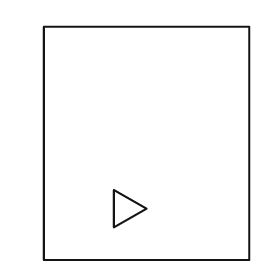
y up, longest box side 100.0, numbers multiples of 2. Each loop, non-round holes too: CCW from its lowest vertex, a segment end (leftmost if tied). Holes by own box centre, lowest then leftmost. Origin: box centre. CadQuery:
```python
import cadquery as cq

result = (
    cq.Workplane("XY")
    .moveTo(-44.0, -50.0)
    .lineTo(44.0, -50.0)
    .lineTo(44.0, 50.0)
    .lineTo(-44.0, 50.0)
    .close()
    .moveTo(-14.0, -36.0)
    .lineTo(0.0, -28.0)
    .lineTo(-14.0, -20.0)
    .close()
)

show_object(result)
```